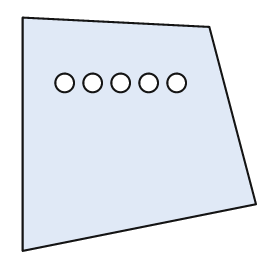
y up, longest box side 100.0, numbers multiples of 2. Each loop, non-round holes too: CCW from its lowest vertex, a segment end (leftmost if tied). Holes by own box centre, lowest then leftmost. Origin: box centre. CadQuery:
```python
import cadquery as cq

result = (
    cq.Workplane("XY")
    .moveTo(-50.0, -50.0)
    .lineTo(50.0, -30.0)
    .lineTo(30.0, 46.0)
    .lineTo(-50.0, 50.0)
    .close()
    .moveTo(-32.0, 22.0)
    .circle(4.0)
    .moveTo(-20.0, 22.0)
    .circle(4.0)
    .moveTo(-8.0, 22.0)
    .circle(4.0)
    .moveTo(4.0, 22.0)
    .circle(4.0)
    .moveTo(16.0, 22.0)
    .circle(4.0)
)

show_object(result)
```